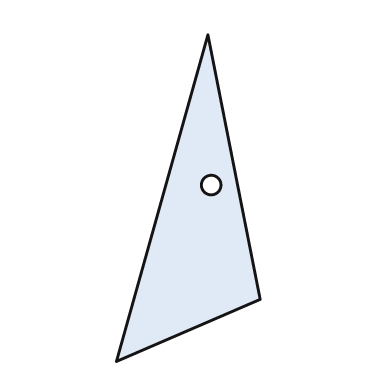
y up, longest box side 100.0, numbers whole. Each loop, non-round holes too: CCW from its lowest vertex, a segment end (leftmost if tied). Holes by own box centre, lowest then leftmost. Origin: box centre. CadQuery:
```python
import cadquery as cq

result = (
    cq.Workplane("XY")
    .moveTo(-22.0, -50.0)
    .lineTo(22.0, -31.0)
    .lineTo(6.0, 50.0)
    .close()
    .moveTo(7.0, 4.0)
    .circle(3.0)
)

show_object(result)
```